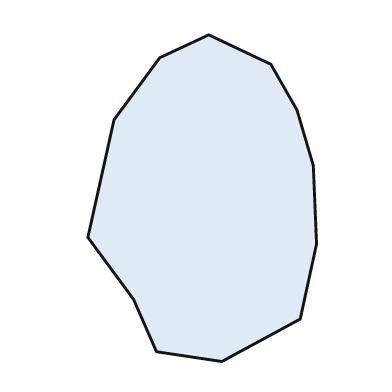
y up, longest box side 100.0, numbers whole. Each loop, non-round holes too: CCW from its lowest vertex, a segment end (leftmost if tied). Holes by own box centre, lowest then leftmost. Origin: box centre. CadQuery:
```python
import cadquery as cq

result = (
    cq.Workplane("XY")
    .moveTo(6.0, -50.0)
    .lineTo(30.0, -37.0)
    .lineTo(35.0, -14.0)
    .lineTo(34.0, 10.0)
    .lineTo(29.0, 27.0)
    .lineTo(21.0, 41.0)
    .lineTo(2.0, 50.0)
    .lineTo(-13.0, 43.0)
    .lineTo(-27.0, 24.0)
    .lineTo(-35.0, -12.0)
    .lineTo(-21.0, -31.0)
    .lineTo(-14.0, -47.0)
    .close()
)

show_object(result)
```